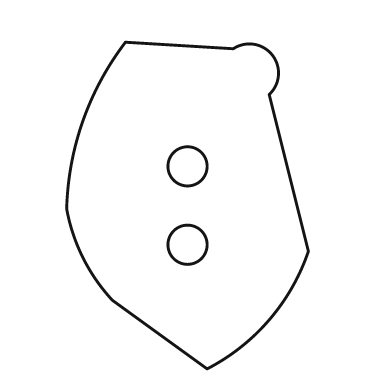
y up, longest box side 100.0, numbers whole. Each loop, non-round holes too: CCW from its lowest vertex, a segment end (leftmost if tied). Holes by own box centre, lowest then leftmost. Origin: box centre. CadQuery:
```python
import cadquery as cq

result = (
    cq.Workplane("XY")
    .moveTo(6.0, -50.0)
    .threePointArc((25.0, -35.0), (37.0, -14.0))
    .lineTo(25.0, 34.0)
    .threePointArc((26.0, 46.0), (14.0, 48.0))
    .lineTo(-19.0, 50.0)
    .threePointArc((-32.0, 26.0), (-37.0, -1.0))
    .threePointArc((-32.0, -16.0), (-23.0, -29.0))
    .close()
    .moveTo(0.0, -12.0)
    .circle(6.0)
    .moveTo(0.0, 12.0)
    .circle(6.0)
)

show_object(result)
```